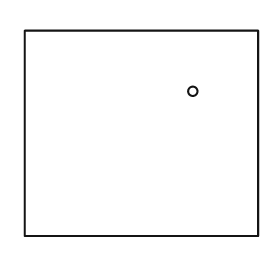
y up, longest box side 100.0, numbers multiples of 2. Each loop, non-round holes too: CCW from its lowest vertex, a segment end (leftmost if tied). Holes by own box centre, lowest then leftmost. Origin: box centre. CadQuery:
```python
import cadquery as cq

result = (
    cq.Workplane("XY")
    .moveTo(-50.0, -44.0)
    .lineTo(50.0, -44.0)
    .lineTo(50.0, 44.0)
    .lineTo(-50.0, 44.0)
    .close()
    .moveTo(22.0, 18.0)
    .circle(2.0)
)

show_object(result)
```